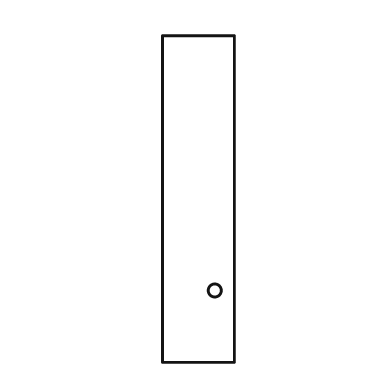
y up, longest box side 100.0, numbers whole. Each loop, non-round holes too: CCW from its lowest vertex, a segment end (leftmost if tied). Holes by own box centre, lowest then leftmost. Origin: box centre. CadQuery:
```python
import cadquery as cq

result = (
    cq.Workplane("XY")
    .moveTo(-11.0, -50.0)
    .lineTo(11.0, -50.0)
    .lineTo(11.0, 50.0)
    .lineTo(-11.0, 50.0)
    .close()
    .moveTo(5.0, -28.0)
    .circle(2.0)
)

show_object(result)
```